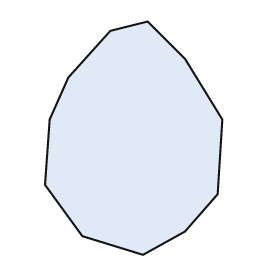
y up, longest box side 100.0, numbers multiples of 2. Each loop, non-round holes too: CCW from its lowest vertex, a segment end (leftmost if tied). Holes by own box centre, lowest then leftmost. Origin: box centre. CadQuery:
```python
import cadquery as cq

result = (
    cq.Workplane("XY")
    .moveTo(4.0, -50.0)
    .lineTo(22.0, -40.0)
    .lineTo(36.0, -24.0)
    .lineTo(38.0, 8.0)
    .lineTo(22.0, 34.0)
    .lineTo(6.0, 50.0)
    .lineTo(-10.0, 46.0)
    .lineTo(-28.0, 26.0)
    .lineTo(-36.0, 8.0)
    .lineTo(-38.0, -20.0)
    .lineTo(-22.0, -42.0)
    .close()
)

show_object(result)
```